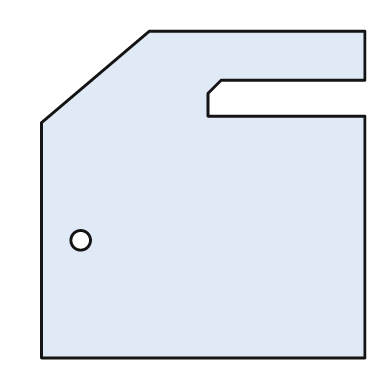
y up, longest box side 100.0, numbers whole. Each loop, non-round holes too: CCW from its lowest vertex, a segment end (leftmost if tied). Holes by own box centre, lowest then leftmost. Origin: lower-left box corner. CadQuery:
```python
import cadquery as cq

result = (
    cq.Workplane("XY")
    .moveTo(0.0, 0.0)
    .lineTo(99.0, 0.0)
    .lineTo(99.0, 74.0)
    .lineTo(51.0, 74.0)
    .lineTo(51.0, 81.0)
    .lineTo(55.0, 85.0)
    .lineTo(99.0, 85.0)
    .lineTo(99.0, 100.0)
    .lineTo(33.0, 100.0)
    .lineTo(0.0, 72.0)
    .close()
    .moveTo(12.0, 36.0)
    .circle(3.0)
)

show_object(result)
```